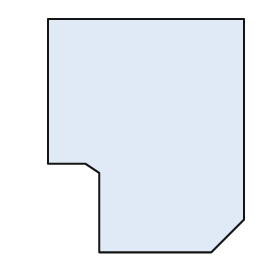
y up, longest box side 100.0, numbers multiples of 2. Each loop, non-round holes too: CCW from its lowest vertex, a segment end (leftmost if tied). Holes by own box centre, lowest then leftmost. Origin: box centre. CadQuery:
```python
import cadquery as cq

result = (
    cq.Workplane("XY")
    .moveTo(-20.0, -50.0)
    .lineTo(28.0, -50.0)
    .lineTo(42.0, -36.0)
    .lineTo(42.0, 50.0)
    .lineTo(-42.0, 50.0)
    .lineTo(-42.0, -12.0)
    .lineTo(-26.0, -12.0)
    .lineTo(-20.0, -16.0)
    .close()
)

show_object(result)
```